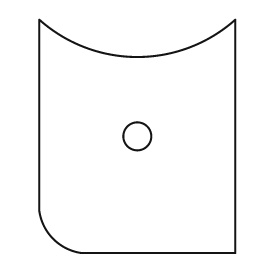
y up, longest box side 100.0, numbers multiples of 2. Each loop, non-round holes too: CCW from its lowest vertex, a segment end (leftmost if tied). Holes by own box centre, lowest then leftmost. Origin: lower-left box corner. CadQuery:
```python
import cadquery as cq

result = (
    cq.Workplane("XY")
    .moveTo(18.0, 0.0)
    .lineTo(84.0, 0.0)
    .lineTo(84.0, 100.0)
    .threePointArc((42.0, 84.0), (0.0, 100.0))
    .lineTo(0.0, 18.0)
    .threePointArc((6.0, 6.0), (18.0, 0.0))
    .close()
    .moveTo(42.0, 50.0)
    .circle(6.0)
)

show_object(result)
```